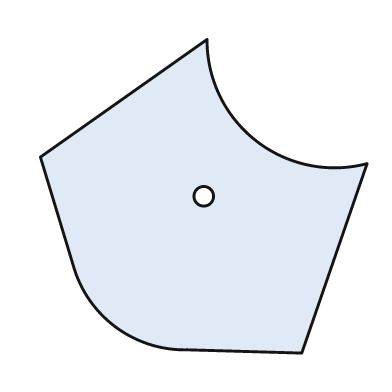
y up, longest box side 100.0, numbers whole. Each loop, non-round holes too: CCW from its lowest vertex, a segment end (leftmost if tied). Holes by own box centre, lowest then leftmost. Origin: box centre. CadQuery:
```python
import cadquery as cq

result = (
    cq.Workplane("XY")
    .moveTo(30.0, -48.0)
    .lineTo(50.0, 10.0)
    .threePointArc((16.0, 17.0), (1.0, 48.0))
    .lineTo(-50.0, 12.0)
    .lineTo(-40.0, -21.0)
    .threePointArc((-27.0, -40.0), (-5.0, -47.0))
    .close()
    .moveTo(0.0, 0.0)
    .circle(3.0)
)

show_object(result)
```